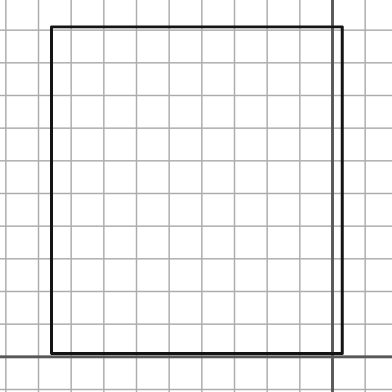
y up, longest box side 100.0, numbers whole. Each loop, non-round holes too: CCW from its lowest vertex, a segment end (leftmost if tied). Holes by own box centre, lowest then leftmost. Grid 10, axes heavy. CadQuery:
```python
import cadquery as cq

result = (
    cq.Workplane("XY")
    .moveTo(-86.0, 1.0)
    .lineTo(3.0, 1.0)
    .lineTo(3.0, 101.0)
    .lineTo(-86.0, 101.0)
    .close()
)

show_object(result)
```